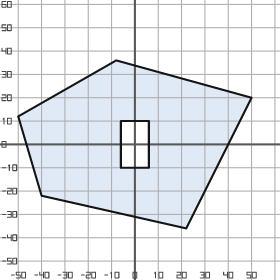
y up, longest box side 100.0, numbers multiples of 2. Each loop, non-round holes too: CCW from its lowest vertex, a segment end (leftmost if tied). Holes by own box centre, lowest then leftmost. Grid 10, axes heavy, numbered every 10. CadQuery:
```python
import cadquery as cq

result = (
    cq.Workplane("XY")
    .moveTo(22.0, -36.0)
    .lineTo(50.0, 20.0)
    .lineTo(-8.0, 36.0)
    .lineTo(-50.0, 12.0)
    .lineTo(-40.0, -22.0)
    .close()
    .moveTo(-6.0, -10.0)
    .lineTo(6.0, -10.0)
    .lineTo(6.0, 10.0)
    .lineTo(-6.0, 10.0)
    .close()
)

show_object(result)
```